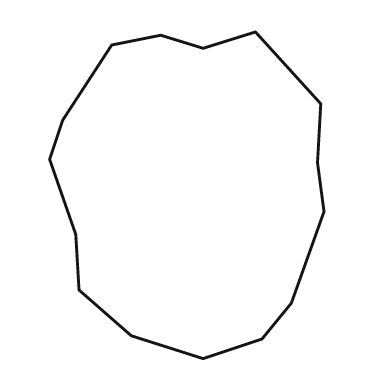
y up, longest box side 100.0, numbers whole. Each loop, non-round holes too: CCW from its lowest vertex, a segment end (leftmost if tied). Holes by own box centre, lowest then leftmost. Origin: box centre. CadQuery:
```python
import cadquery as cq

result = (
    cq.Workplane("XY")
    .moveTo(5.0, -50.0)
    .lineTo(23.0, -44.0)
    .lineTo(32.0, -33.0)
    .lineTo(42.0, -5.0)
    .lineTo(40.0, 10.0)
    .lineTo(41.0, 28.0)
    .lineTo(21.0, 50.0)
    .lineTo(5.0, 45.0)
    .lineTo(-8.0, 49.0)
    .lineTo(-23.0, 46.0)
    .lineTo(-38.0, 23.0)
    .lineTo(-42.0, 11.0)
    .lineTo(-34.0, -12.0)
    .lineTo(-33.0, -29.0)
    .lineTo(-17.0, -43.0)
    .close()
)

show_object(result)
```